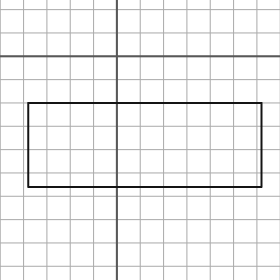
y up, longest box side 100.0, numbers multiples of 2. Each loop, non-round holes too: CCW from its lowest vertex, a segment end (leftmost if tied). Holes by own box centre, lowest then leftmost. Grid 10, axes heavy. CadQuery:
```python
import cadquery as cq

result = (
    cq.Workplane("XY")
    .moveTo(-38.0, -56.0)
    .lineTo(62.0, -56.0)
    .lineTo(62.0, -20.0)
    .lineTo(-38.0, -20.0)
    .close()
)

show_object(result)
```